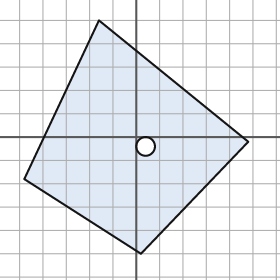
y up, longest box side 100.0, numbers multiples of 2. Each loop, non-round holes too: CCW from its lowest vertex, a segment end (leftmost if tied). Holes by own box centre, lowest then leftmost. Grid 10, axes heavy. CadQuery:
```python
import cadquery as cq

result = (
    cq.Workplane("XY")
    .moveTo(2.0, -50.0)
    .lineTo(48.0, -2.0)
    .lineTo(-16.0, 50.0)
    .lineTo(-48.0, -18.0)
    .close()
    .moveTo(4.0, -4.0)
    .circle(4.0)
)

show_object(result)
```